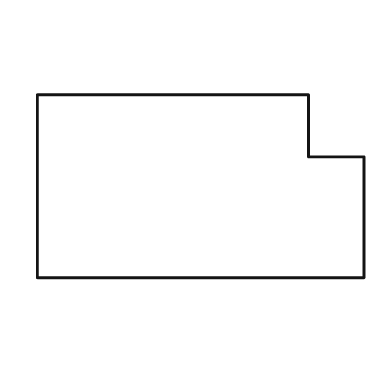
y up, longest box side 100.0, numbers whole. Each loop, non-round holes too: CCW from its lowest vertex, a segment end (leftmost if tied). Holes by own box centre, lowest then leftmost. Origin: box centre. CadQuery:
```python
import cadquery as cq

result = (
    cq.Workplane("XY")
    .moveTo(-50.0, -28.0)
    .lineTo(50.0, -28.0)
    .lineTo(50.0, 9.0)
    .lineTo(33.0, 9.0)
    .lineTo(33.0, 28.0)
    .lineTo(-50.0, 28.0)
    .close()
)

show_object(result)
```